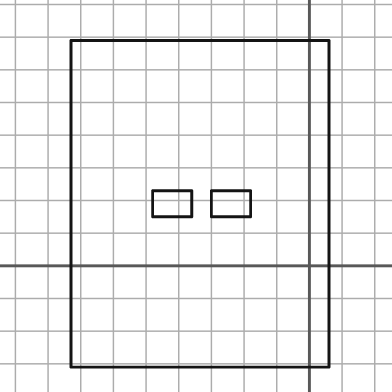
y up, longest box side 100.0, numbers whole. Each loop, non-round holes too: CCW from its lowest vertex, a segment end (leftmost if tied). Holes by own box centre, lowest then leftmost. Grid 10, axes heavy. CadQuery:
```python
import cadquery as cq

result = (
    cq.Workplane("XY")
    .moveTo(-73.0, -31.0)
    .lineTo(6.0, -31.0)
    .lineTo(6.0, 69.0)
    .lineTo(-73.0, 69.0)
    .close()
    .moveTo(-48.0, 15.0)
    .lineTo(-36.0, 15.0)
    .lineTo(-36.0, 23.0)
    .lineTo(-48.0, 23.0)
    .close()
    .moveTo(-30.0, 15.0)
    .lineTo(-18.0, 15.0)
    .lineTo(-18.0, 23.0)
    .lineTo(-30.0, 23.0)
    .close()
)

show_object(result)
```